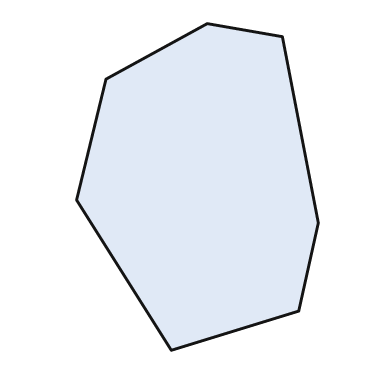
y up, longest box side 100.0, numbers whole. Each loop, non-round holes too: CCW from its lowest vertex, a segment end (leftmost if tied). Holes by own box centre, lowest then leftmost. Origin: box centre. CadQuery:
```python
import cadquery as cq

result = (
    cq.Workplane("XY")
    .moveTo(-8.0, -50.0)
    .lineTo(31.0, -38.0)
    .lineTo(37.0, -11.0)
    .lineTo(26.0, 46.0)
    .lineTo(3.0, 50.0)
    .lineTo(-28.0, 33.0)
    .lineTo(-37.0, -4.0)
    .close()
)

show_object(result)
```